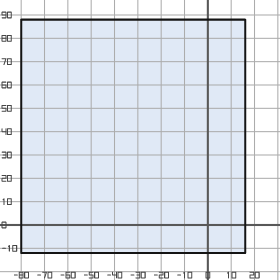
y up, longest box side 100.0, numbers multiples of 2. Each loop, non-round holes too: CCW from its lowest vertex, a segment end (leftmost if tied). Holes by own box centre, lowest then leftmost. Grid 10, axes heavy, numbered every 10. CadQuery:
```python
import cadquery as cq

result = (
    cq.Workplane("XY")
    .moveTo(-80.0, -12.0)
    .lineTo(16.0, -12.0)
    .lineTo(16.0, 88.0)
    .lineTo(-80.0, 88.0)
    .close()
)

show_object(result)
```